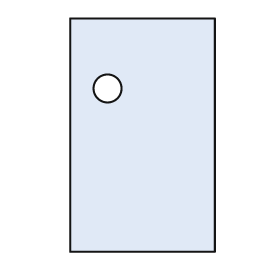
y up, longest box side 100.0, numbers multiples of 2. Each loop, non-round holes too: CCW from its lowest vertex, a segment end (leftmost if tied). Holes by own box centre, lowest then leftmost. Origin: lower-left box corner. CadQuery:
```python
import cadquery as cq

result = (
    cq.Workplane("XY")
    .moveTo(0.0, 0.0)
    .lineTo(62.0, 0.0)
    .lineTo(62.0, 100.0)
    .lineTo(0.0, 100.0)
    .close()
    .moveTo(16.0, 70.0)
    .circle(6.0)
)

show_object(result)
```